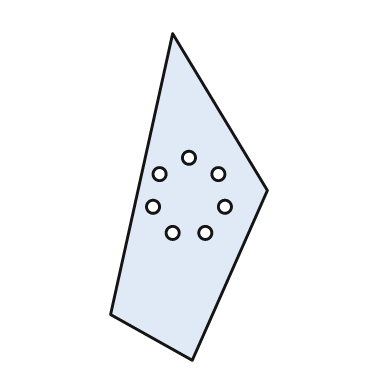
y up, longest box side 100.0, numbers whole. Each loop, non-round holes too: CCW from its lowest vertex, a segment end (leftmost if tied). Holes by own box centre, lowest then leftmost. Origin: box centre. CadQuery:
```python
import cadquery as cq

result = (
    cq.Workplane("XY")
    .moveTo(1.0, -50.0)
    .lineTo(24.0, 2.0)
    .lineTo(-5.0, 50.0)
    .lineTo(-24.0, -36.0)
    .close()
    .moveTo(-5.0, -11.0)
    .circle(2.0)
    .moveTo(5.0, -11.0)
    .circle(2.0)
    .moveTo(-11.0, -3.0)
    .circle(2.0)
    .moveTo(11.0, -3.0)
    .circle(2.0)
    .moveTo(-9.0, 7.0)
    .circle(2.0)
    .moveTo(9.0, 7.0)
    .circle(2.0)
    .moveTo(0.0, 12.0)
    .circle(2.0)
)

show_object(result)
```